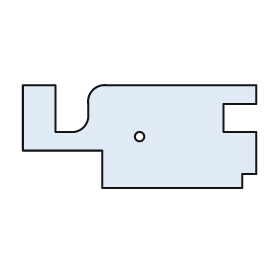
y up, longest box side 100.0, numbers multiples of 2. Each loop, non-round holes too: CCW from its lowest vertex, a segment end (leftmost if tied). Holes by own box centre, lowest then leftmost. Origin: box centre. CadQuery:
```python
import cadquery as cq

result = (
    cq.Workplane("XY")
    .moveTo(-16.0, -22.0)
    .lineTo(44.0, -22.0)
    .lineTo(44.0, -16.0)
    .lineTo(50.0, -16.0)
    .lineTo(50.0, 2.0)
    .lineTo(36.0, 2.0)
    .lineTo(36.0, 14.0)
    .lineTo(50.0, 14.0)
    .lineTo(50.0, 22.0)
    .lineTo(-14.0, 22.0)
    .threePointArc((-20.0, 20.0), (-22.0, 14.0))
    .lineTo(-22.0, 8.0)
    .threePointArc((-24.0, 4.0), (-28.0, 2.0))
    .lineTo(-36.0, 2.0)
    .lineTo(-36.0, 22.0)
    .lineTo(-50.0, 22.0)
    .lineTo(-50.0, -6.0)
    .lineTo(-16.0, -6.0)
    .close()
    .moveTo(0.0, 0.0)
    .circle(2.0)
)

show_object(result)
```